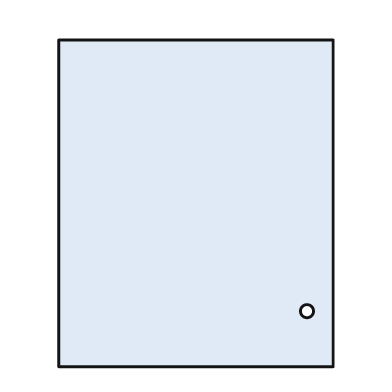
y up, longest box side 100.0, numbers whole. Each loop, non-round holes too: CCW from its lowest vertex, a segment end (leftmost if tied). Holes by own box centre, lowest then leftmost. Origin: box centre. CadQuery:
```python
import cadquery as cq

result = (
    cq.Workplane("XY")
    .moveTo(-42.0, -50.0)
    .lineTo(42.0, -50.0)
    .lineTo(42.0, 50.0)
    .lineTo(-42.0, 50.0)
    .close()
    .moveTo(34.0, -33.0)
    .circle(2.0)
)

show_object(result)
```